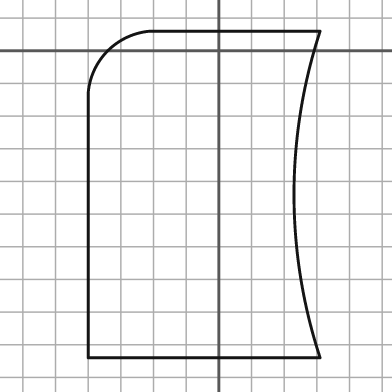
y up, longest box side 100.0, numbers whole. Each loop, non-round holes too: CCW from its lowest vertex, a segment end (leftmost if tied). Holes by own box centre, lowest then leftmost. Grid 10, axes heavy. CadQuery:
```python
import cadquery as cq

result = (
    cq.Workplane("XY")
    .moveTo(-40.0, -94.0)
    .lineTo(31.0, -94.0)
    .threePointArc((23.0, -44.0), (31.0, 6.0))
    .lineTo(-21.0, 6.0)
    .threePointArc((-34.0, 0.0), (-40.0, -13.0))
    .close()
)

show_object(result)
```